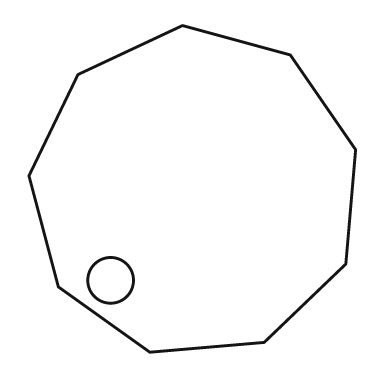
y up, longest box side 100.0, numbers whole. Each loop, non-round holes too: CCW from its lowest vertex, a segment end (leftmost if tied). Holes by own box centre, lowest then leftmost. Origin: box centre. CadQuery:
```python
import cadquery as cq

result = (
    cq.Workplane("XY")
    .moveTo(-13.0, -50.0)
    .lineTo(22.0, -47.0)
    .lineTo(47.0, -23.0)
    .lineTo(50.0, 12.0)
    .lineTo(30.0, 41.0)
    .lineTo(-3.0, 50.0)
    .lineTo(-35.0, 35.0)
    .lineTo(-50.0, 4.0)
    .lineTo(-41.0, -30.0)
    .close()
    .moveTo(-25.0, -28.0)
    .circle(7.0)
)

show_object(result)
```